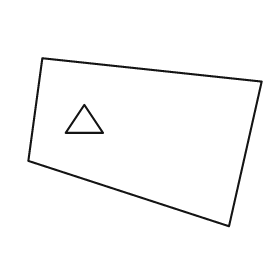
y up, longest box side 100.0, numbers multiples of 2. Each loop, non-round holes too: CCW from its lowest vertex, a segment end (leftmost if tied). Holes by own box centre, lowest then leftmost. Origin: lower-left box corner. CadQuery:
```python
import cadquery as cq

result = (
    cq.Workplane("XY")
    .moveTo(86.0, 0.0)
    .lineTo(100.0, 62.0)
    .lineTo(6.0, 72.0)
    .lineTo(0.0, 28.0)
    .close()
    .moveTo(16.0, 40.0)
    .lineTo(32.0, 40.0)
    .lineTo(24.0, 52.0)
    .close()
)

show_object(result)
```